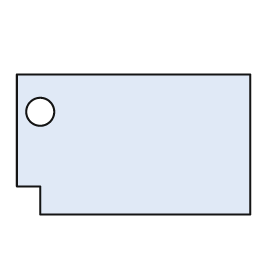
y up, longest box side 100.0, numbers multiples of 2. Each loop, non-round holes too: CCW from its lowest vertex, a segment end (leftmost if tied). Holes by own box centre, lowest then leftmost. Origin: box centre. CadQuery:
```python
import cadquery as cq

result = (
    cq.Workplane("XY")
    .moveTo(-40.0, -30.0)
    .lineTo(50.0, -30.0)
    .lineTo(50.0, 30.0)
    .lineTo(-50.0, 30.0)
    .lineTo(-50.0, -18.0)
    .lineTo(-40.0, -18.0)
    .close()
    .moveTo(-40.0, 14.0)
    .circle(6.0)
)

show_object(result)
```